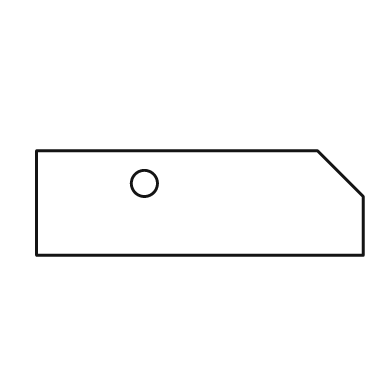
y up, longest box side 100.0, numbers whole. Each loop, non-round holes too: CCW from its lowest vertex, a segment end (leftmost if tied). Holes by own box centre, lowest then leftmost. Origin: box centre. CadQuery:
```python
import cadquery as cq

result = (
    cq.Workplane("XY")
    .moveTo(-50.0, -16.0)
    .lineTo(50.0, -16.0)
    .lineTo(50.0, 2.0)
    .lineTo(36.0, 16.0)
    .lineTo(-50.0, 16.0)
    .close()
    .moveTo(-17.0, 6.0)
    .circle(4.0)
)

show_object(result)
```